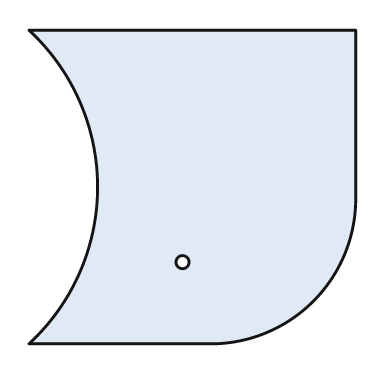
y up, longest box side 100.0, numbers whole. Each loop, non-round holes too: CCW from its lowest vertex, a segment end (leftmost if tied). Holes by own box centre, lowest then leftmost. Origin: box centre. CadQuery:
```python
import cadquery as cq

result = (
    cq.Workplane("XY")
    .moveTo(-50.0, -48.0)
    .lineTo(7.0, -48.0)
    .threePointArc((37.0, -35.0), (50.0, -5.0))
    .lineTo(50.0, 48.0)
    .lineTo(-50.0, 48.0)
    .threePointArc((-29.0, 0.0), (-50.0, -48.0))
    .close()
    .moveTo(-3.0, -23.0)
    .circle(2.0)
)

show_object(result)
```